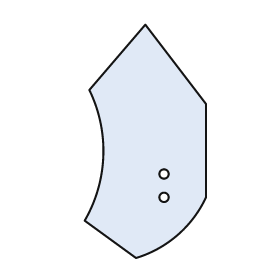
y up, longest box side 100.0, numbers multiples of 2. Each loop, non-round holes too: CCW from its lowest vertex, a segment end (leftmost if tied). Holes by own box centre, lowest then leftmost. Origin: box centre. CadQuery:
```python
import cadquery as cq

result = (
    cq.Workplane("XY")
    .moveTo(-4.0, -50.0)
    .threePointArc((14.0, -40.0), (26.0, -24.0))
    .lineTo(26.0, 16.0)
    .lineTo(0.0, 50.0)
    .lineTo(-24.0, 22.0)
    .threePointArc((-18.0, -6.0), (-26.0, -34.0))
    .close()
    .moveTo(8.0, -24.0)
    .circle(2.0)
    .moveTo(8.0, -14.0)
    .circle(2.0)
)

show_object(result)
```